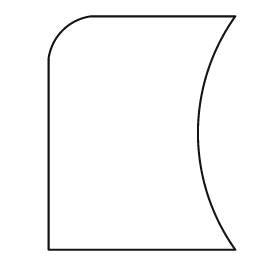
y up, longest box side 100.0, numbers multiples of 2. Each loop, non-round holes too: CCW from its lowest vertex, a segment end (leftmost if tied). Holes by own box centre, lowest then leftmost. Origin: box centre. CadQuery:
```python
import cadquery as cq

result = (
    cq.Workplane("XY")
    .moveTo(-40.0, -50.0)
    .lineTo(40.0, -50.0)
    .threePointArc((24.0, 0.0), (40.0, 50.0))
    .lineTo(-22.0, 50.0)
    .threePointArc((-34.0, 44.0), (-40.0, 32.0))
    .close()
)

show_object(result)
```